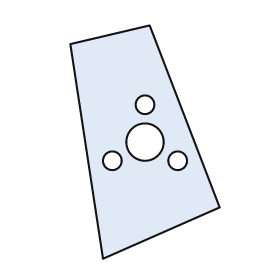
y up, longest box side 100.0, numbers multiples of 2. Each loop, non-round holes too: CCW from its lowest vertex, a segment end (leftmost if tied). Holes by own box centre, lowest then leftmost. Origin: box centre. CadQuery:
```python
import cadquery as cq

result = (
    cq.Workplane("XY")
    .moveTo(-18.0, -50.0)
    .lineTo(32.0, -28.0)
    .lineTo(2.0, 50.0)
    .lineTo(-32.0, 42.0)
    .close()
    .moveTo(-14.0, -8.0)
    .circle(4.0)
    .moveTo(14.0, -8.0)
    .circle(4.0)
    .moveTo(0.0, 0.0)
    .circle(8.0)
    .moveTo(0.0, 16.0)
    .circle(4.0)
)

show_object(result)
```